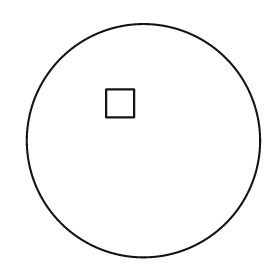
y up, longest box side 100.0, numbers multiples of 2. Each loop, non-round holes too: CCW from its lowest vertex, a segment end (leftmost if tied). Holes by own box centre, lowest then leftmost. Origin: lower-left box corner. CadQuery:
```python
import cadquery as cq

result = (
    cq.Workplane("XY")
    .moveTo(50.0, 50.0)
    .circle(50.0)
    .moveTo(34.0, 60.0)
    .lineTo(46.0, 60.0)
    .lineTo(46.0, 72.0)
    .lineTo(34.0, 72.0)
    .close()
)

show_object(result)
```